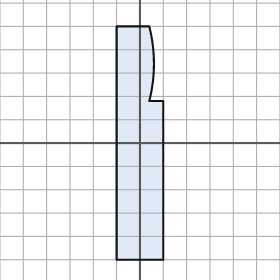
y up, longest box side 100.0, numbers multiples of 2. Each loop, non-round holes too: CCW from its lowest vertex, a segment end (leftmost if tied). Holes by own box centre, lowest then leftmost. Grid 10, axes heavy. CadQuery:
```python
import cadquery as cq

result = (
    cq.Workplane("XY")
    .moveTo(-10.0, -50.0)
    .lineTo(10.0, -50.0)
    .lineTo(10.0, 18.0)
    .lineTo(4.0, 18.0)
    .threePointArc((6.0, 34.0), (4.0, 50.0))
    .lineTo(-10.0, 50.0)
    .close()
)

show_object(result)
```